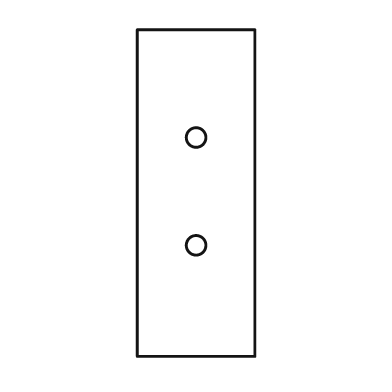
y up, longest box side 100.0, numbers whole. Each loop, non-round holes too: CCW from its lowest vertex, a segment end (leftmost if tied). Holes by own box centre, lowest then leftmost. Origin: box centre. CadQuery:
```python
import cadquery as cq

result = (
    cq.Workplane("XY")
    .moveTo(-18.0, -50.0)
    .lineTo(18.0, -50.0)
    .lineTo(18.0, 50.0)
    .lineTo(-18.0, 50.0)
    .close()
    .moveTo(0.0, -16.0)
    .circle(3.0)
    .moveTo(0.0, 17.0)
    .circle(3.0)
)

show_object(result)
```